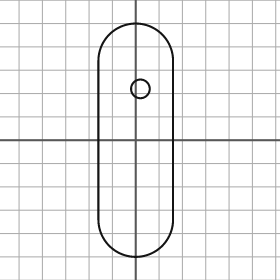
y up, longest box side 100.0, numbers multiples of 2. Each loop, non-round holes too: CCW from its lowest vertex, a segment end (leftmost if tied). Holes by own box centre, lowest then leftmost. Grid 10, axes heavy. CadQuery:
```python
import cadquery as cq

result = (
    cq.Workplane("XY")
    .moveTo(-16.0, -34.0)
    .threePointArc((0.0, -50.0), (16.0, -34.0))
    .lineTo(16.0, 34.0)
    .threePointArc((0.0, 50.0), (-16.0, 34.0))
    .close()
    .moveTo(2.0, 22.0)
    .circle(4.0)
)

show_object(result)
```